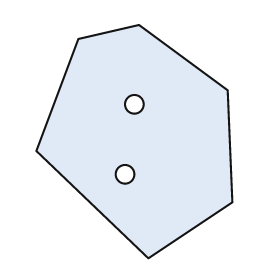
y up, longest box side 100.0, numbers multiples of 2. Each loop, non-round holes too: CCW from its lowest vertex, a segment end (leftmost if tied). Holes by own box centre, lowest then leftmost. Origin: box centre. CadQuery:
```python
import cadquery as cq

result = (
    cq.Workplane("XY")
    .moveTo(6.0, -50.0)
    .lineTo(42.0, -26.0)
    .lineTo(40.0, 22.0)
    .lineTo(2.0, 50.0)
    .lineTo(-24.0, 44.0)
    .lineTo(-42.0, -4.0)
    .close()
    .moveTo(-4.0, -14.0)
    .circle(4.0)
    .moveTo(0.0, 16.0)
    .circle(4.0)
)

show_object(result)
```